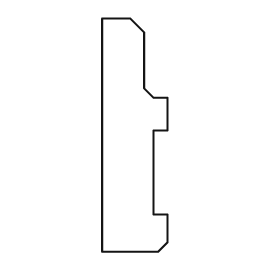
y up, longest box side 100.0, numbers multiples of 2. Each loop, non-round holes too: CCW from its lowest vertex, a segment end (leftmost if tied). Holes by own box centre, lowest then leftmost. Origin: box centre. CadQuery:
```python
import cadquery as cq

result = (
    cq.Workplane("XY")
    .moveTo(-14.0, -50.0)
    .lineTo(10.0, -50.0)
    .lineTo(14.0, -46.0)
    .lineTo(14.0, -34.0)
    .lineTo(8.0, -34.0)
    .lineTo(8.0, 2.0)
    .lineTo(14.0, 2.0)
    .lineTo(14.0, 16.0)
    .lineTo(8.0, 16.0)
    .lineTo(4.0, 20.0)
    .lineTo(4.0, 44.0)
    .lineTo(-2.0, 50.0)
    .lineTo(-14.0, 50.0)
    .close()
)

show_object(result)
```